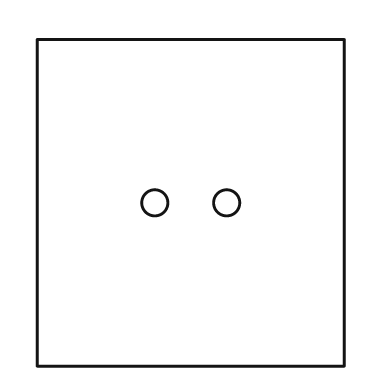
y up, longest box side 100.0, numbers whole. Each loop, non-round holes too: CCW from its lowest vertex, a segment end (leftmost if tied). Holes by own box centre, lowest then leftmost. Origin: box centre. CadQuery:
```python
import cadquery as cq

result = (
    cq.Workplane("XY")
    .moveTo(-47.0, -50.0)
    .lineTo(47.0, -50.0)
    .lineTo(47.0, 50.0)
    .lineTo(-47.0, 50.0)
    .close()
    .moveTo(-11.0, 0.0)
    .circle(4.0)
    .moveTo(11.0, 0.0)
    .circle(4.0)
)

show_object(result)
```